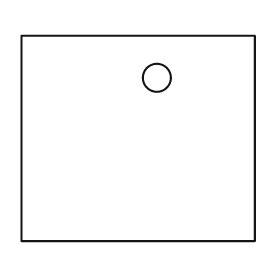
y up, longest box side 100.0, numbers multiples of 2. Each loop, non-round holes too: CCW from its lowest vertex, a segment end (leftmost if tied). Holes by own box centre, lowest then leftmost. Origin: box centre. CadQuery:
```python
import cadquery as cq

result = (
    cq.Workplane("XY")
    .moveTo(-50.0, -44.0)
    .lineTo(50.0, -44.0)
    .lineTo(50.0, 44.0)
    .lineTo(-50.0, 44.0)
    .close()
    .moveTo(8.0, 26.0)
    .circle(6.0)
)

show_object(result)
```